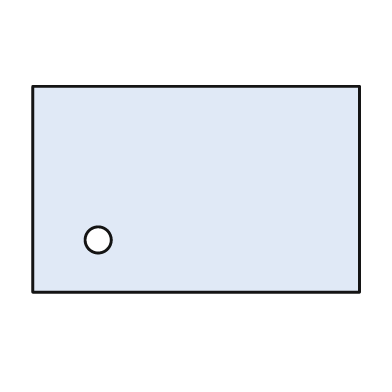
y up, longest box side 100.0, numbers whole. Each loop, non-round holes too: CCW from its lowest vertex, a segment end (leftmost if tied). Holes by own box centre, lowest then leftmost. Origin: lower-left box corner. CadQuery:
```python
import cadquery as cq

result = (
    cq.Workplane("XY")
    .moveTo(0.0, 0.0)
    .lineTo(100.0, 0.0)
    .lineTo(100.0, 63.0)
    .lineTo(0.0, 63.0)
    .close()
    .moveTo(20.0, 16.0)
    .circle(4.0)
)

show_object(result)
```